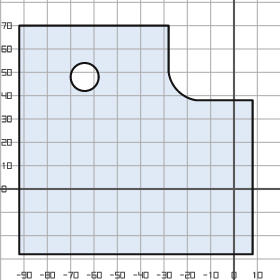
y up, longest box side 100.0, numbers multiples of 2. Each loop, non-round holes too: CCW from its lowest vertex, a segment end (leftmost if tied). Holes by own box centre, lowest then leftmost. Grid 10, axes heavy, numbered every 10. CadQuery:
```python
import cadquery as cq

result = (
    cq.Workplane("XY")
    .moveTo(-92.0, -28.0)
    .lineTo(8.0, -28.0)
    .lineTo(8.0, 38.0)
    .lineTo(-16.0, 38.0)
    .threePointArc((-24.0, 42.0), (-28.0, 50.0))
    .lineTo(-28.0, 70.0)
    .lineTo(-92.0, 70.0)
    .close()
    .moveTo(-64.0, 48.0)
    .circle(6.0)
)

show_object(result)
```